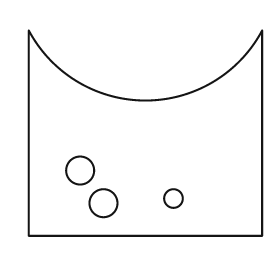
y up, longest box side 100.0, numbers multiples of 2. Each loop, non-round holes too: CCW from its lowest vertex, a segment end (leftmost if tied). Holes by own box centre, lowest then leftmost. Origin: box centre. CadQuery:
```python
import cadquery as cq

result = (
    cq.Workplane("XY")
    .moveTo(-50.0, -44.0)
    .lineTo(50.0, -44.0)
    .lineTo(50.0, 44.0)
    .threePointArc((0.0, 14.0), (-50.0, 44.0))
    .close()
    .moveTo(-18.0, -30.0)
    .circle(6.0)
    .moveTo(12.0, -28.0)
    .circle(4.0)
    .moveTo(-28.0, -16.0)
    .circle(6.0)
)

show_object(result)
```